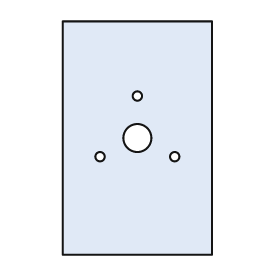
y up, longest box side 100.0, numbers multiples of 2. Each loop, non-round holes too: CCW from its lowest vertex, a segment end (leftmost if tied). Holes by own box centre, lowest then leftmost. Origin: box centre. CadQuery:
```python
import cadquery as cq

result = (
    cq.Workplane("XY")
    .moveTo(-32.0, -50.0)
    .lineTo(32.0, -50.0)
    .lineTo(32.0, 50.0)
    .lineTo(-32.0, 50.0)
    .close()
    .moveTo(-16.0, -8.0)
    .circle(2.0)
    .moveTo(16.0, -8.0)
    .circle(2.0)
    .moveTo(0.0, 0.0)
    .circle(6.0)
    .moveTo(0.0, 18.0)
    .circle(2.0)
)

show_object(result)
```